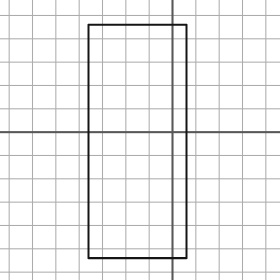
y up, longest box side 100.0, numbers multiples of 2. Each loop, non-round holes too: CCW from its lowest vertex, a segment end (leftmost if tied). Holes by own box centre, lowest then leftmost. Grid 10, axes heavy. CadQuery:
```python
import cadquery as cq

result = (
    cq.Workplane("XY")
    .moveTo(-36.0, -54.0)
    .lineTo(6.0, -54.0)
    .lineTo(6.0, 46.0)
    .lineTo(-36.0, 46.0)
    .close()
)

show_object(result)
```